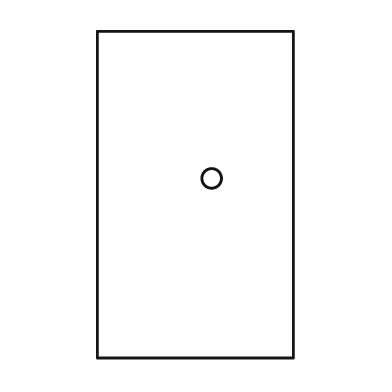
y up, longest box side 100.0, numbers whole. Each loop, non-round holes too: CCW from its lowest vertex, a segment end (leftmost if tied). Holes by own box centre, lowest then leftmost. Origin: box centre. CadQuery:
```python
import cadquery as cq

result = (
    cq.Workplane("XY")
    .moveTo(-30.0, -50.0)
    .lineTo(30.0, -50.0)
    .lineTo(30.0, 50.0)
    .lineTo(-30.0, 50.0)
    .close()
    .moveTo(5.0, 5.0)
    .circle(3.0)
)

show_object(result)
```